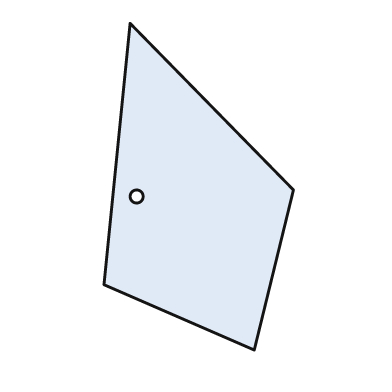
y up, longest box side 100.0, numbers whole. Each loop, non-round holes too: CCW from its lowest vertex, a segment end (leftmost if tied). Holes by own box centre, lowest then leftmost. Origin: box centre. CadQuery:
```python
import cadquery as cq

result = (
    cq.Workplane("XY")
    .moveTo(17.0, -50.0)
    .lineTo(29.0, -1.0)
    .lineTo(-21.0, 50.0)
    .lineTo(-29.0, -30.0)
    .close()
    .moveTo(-19.0, -3.0)
    .circle(2.0)
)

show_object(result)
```